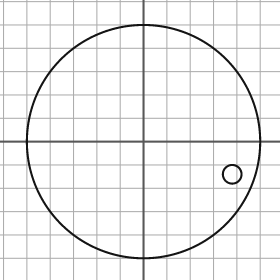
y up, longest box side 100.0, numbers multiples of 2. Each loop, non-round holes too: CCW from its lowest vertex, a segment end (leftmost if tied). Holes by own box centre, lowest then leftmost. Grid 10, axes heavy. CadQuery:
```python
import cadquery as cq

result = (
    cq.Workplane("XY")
    .moveTo(0.0, 0.0)
    .circle(50.0)
    .moveTo(38.0, -14.0)
    .circle(4.0)
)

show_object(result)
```